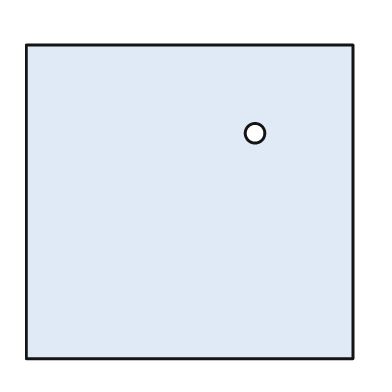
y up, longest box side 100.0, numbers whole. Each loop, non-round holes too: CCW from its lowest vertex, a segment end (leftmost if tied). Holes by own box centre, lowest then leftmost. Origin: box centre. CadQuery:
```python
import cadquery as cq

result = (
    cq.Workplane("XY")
    .moveTo(-50.0, -48.0)
    .lineTo(50.0, -48.0)
    .lineTo(50.0, 48.0)
    .lineTo(-50.0, 48.0)
    .close()
    .moveTo(20.0, 21.0)
    .circle(3.0)
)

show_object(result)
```